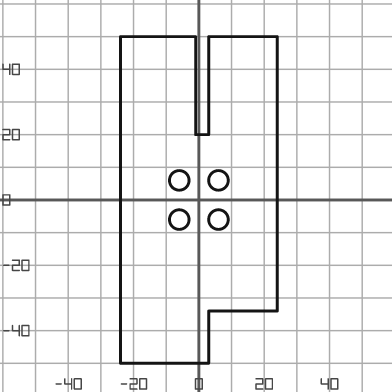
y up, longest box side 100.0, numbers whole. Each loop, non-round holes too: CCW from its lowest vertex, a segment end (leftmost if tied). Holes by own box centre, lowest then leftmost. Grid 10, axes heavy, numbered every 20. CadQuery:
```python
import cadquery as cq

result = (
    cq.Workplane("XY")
    .moveTo(-24.0, -50.0)
    .lineTo(3.0, -50.0)
    .lineTo(3.0, -34.0)
    .lineTo(24.0, -34.0)
    .lineTo(24.0, 50.0)
    .lineTo(3.0, 50.0)
    .lineTo(3.0, 20.0)
    .lineTo(-1.0, 20.0)
    .lineTo(-1.0, 50.0)
    .lineTo(-24.0, 50.0)
    .close()
    .moveTo(-6.0, -6.0)
    .circle(3.0)
    .moveTo(6.0, -6.0)
    .circle(3.0)
    .moveTo(-6.0, 6.0)
    .circle(3.0)
    .moveTo(6.0, 6.0)
    .circle(3.0)
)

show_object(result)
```